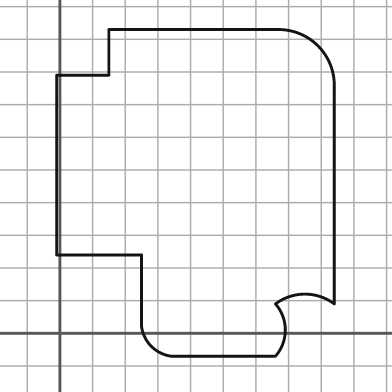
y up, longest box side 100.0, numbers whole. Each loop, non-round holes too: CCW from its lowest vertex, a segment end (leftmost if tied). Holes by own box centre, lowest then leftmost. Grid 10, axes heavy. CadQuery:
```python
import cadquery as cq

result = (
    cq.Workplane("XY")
    .moveTo(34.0, -7.0)
    .lineTo(66.0, -7.0)
    .threePointArc((69.0, 1.0), (66.0, 9.0))
    .threePointArc((75.0, 12.0), (84.0, 9.0))
    .lineTo(84.0, 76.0)
    .threePointArc((79.0, 88.0), (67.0, 93.0))
    .lineTo(15.0, 93.0)
    .lineTo(15.0, 79.0)
    .lineTo(-1.0, 79.0)
    .lineTo(-1.0, 24.0)
    .lineTo(25.0, 24.0)
    .lineTo(25.0, 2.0)
    .threePointArc((28.0, -4.0), (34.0, -7.0))
    .close()
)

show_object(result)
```